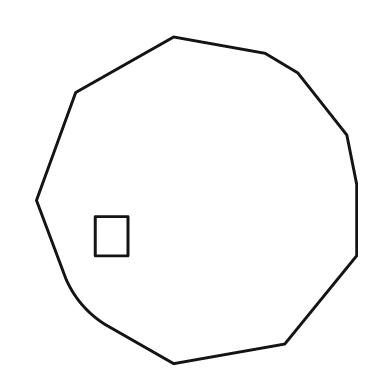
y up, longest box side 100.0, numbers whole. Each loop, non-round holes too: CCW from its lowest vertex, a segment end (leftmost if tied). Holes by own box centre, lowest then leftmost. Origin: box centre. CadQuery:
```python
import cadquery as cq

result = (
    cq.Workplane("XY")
    .moveTo(-7.0, -50.0)
    .lineTo(27.0, -44.0)
    .lineTo(49.0, -17.0)
    .lineTo(49.0, 5.0)
    .lineTo(46.0, 20.0)
    .lineTo(31.0, 39.0)
    .lineTo(21.0, 45.0)
    .lineTo(-7.0, 50.0)
    .lineTo(-37.0, 33.0)
    .lineTo(-49.0, 0.0)
    .lineTo(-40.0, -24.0)
    .threePointArc((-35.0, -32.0), (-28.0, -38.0))
    .close()
    .moveTo(-31.0, -17.0)
    .lineTo(-21.0, -17.0)
    .lineTo(-21.0, -5.0)
    .lineTo(-31.0, -5.0)
    .close()
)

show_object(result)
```